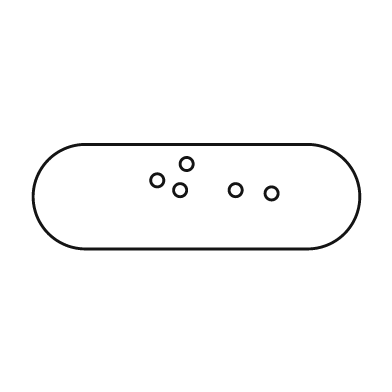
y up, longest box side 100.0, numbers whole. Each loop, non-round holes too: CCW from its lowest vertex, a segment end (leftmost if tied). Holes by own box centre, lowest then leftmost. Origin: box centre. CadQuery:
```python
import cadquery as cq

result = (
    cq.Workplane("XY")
    .moveTo(-34.0, -16.0)
    .lineTo(34.0, -16.0)
    .threePointArc((50.0, 0.0), (34.0, 16.0))
    .lineTo(-34.0, 16.0)
    .threePointArc((-50.0, 0.0), (-34.0, -16.0))
    .close()
    .moveTo(23.0, 1.0)
    .circle(2.0)
    .moveTo(-5.0, 2.0)
    .circle(2.0)
    .moveTo(12.0, 2.0)
    .circle(2.0)
    .moveTo(-12.0, 5.0)
    .circle(2.0)
    .moveTo(-3.0, 10.0)
    .circle(2.0)
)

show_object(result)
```